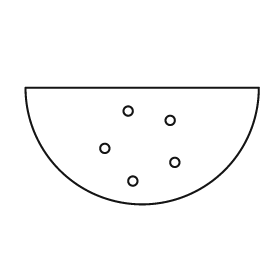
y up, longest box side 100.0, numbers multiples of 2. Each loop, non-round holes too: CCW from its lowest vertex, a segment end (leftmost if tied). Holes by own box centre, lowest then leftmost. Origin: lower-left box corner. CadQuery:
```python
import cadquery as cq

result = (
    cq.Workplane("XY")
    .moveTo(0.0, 50.0)
    .threePointArc((50.0, 0.0), (100.0, 50.0))
    .close()
    .moveTo(46.0, 10.0)
    .circle(2.0)
    .moveTo(64.0, 18.0)
    .circle(2.0)
    .moveTo(34.0, 24.0)
    .circle(2.0)
    .moveTo(62.0, 36.0)
    .circle(2.0)
    .moveTo(44.0, 40.0)
    .circle(2.0)
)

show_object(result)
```